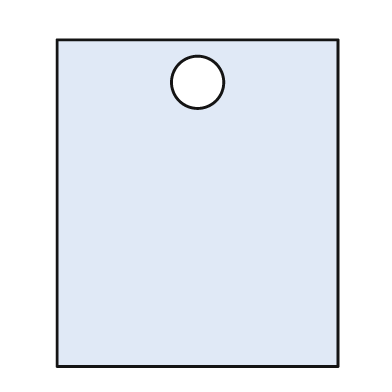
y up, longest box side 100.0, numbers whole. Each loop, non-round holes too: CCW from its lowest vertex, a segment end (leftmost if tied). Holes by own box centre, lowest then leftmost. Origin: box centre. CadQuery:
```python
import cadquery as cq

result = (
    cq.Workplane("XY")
    .moveTo(-43.0, -50.0)
    .lineTo(43.0, -50.0)
    .lineTo(43.0, 50.0)
    .lineTo(-43.0, 50.0)
    .close()
    .moveTo(0.0, 37.0)
    .circle(8.0)
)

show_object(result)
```